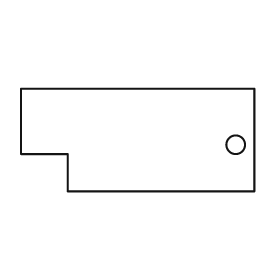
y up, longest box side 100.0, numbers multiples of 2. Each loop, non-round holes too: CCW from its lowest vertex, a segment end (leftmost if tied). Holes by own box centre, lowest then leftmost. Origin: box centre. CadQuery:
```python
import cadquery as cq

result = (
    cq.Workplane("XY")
    .moveTo(-30.0, -22.0)
    .lineTo(50.0, -22.0)
    .lineTo(50.0, 22.0)
    .lineTo(-50.0, 22.0)
    .lineTo(-50.0, -6.0)
    .lineTo(-30.0, -6.0)
    .close()
    .moveTo(42.0, -2.0)
    .circle(4.0)
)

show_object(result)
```